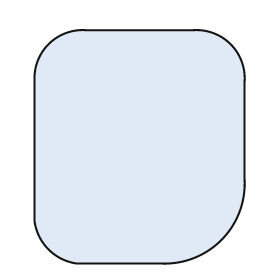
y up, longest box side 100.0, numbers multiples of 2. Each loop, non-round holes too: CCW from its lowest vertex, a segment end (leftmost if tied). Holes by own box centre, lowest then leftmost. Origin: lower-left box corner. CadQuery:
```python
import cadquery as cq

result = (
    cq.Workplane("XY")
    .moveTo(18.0, 0.0)
    .lineTo(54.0, 0.0)
    .threePointArc((80.0, 10.0), (90.0, 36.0))
    .lineTo(90.0, 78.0)
    .threePointArc((84.0, 94.0), (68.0, 100.0))
    .lineTo(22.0, 100.0)
    .threePointArc((6.0, 94.0), (0.0, 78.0))
    .lineTo(0.0, 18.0)
    .threePointArc((6.0, 6.0), (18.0, 0.0))
    .close()
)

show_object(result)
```